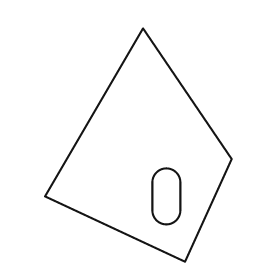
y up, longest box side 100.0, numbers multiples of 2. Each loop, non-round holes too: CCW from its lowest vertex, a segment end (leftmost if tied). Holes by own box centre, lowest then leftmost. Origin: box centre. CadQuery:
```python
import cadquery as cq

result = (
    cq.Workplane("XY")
    .moveTo(20.0, -50.0)
    .lineTo(40.0, -6.0)
    .lineTo(2.0, 50.0)
    .lineTo(-40.0, -22.0)
    .close()
    .moveTo(6.0, -28.0)
    .threePointArc((12.0, -34.0), (18.0, -28.0))
    .lineTo(18.0, -16.0)
    .threePointArc((12.0, -10.0), (6.0, -16.0))
    .close()
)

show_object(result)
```